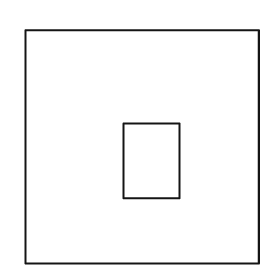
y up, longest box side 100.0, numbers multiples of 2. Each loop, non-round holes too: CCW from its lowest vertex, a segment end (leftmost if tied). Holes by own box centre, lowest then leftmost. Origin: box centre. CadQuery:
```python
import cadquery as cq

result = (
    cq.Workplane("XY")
    .moveTo(-50.0, -50.0)
    .lineTo(50.0, -50.0)
    .lineTo(50.0, 50.0)
    .lineTo(-50.0, 50.0)
    .close()
    .moveTo(-8.0, -22.0)
    .lineTo(16.0, -22.0)
    .lineTo(16.0, 10.0)
    .lineTo(-8.0, 10.0)
    .close()
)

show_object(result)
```